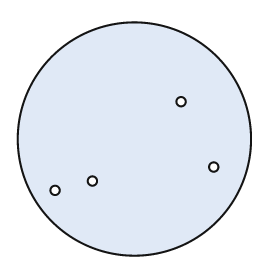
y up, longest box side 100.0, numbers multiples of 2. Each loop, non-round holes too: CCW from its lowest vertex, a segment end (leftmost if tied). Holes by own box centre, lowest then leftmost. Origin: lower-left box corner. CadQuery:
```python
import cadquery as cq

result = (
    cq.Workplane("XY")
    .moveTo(50.0, 50.0)
    .circle(50.0)
    .moveTo(16.0, 28.0)
    .circle(2.0)
    .moveTo(32.0, 32.0)
    .circle(2.0)
    .moveTo(84.0, 38.0)
    .circle(2.0)
    .moveTo(70.0, 66.0)
    .circle(2.0)
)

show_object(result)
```